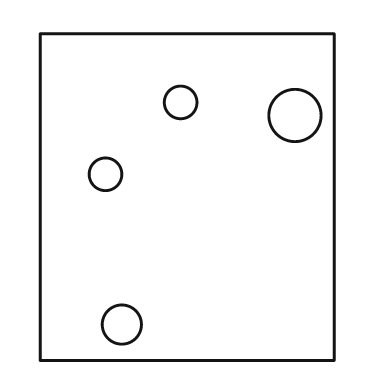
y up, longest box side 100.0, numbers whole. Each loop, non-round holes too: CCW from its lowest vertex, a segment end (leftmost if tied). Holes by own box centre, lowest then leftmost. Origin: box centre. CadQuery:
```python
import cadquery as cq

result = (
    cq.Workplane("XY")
    .moveTo(-45.0, -50.0)
    .lineTo(45.0, -50.0)
    .lineTo(45.0, 50.0)
    .lineTo(-45.0, 50.0)
    .close()
    .moveTo(-20.0, -39.0)
    .circle(6.0)
    .moveTo(-25.0, 7.0)
    .circle(5.0)
    .moveTo(33.0, 25.0)
    .circle(8.0)
    .moveTo(-2.0, 29.0)
    .circle(5.0)
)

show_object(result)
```